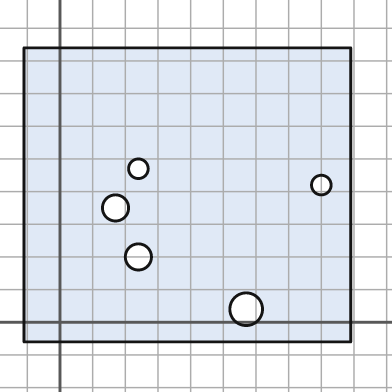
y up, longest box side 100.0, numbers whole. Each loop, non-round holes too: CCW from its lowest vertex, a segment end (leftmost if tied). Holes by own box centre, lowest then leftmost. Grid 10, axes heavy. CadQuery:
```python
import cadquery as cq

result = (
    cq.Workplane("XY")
    .moveTo(-11.0, -6.0)
    .lineTo(89.0, -6.0)
    .lineTo(89.0, 84.0)
    .lineTo(-11.0, 84.0)
    .close()
    .moveTo(57.0, 4.0)
    .circle(5.0)
    .moveTo(24.0, 20.0)
    .circle(4.0)
    .moveTo(17.0, 35.0)
    .circle(4.0)
    .moveTo(80.0, 42.0)
    .circle(3.0)
    .moveTo(24.0, 47.0)
    .circle(3.0)
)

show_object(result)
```